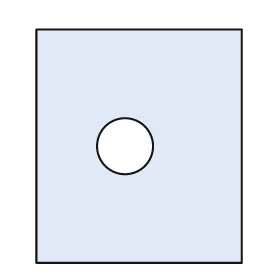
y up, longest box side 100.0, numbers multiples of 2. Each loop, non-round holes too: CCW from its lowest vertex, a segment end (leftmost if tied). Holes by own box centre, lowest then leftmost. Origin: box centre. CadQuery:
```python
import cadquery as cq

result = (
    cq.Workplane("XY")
    .moveTo(-44.0, -50.0)
    .lineTo(44.0, -50.0)
    .lineTo(44.0, 50.0)
    .lineTo(-44.0, 50.0)
    .close()
    .moveTo(-6.0, 0.0)
    .circle(12.0)
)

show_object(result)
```